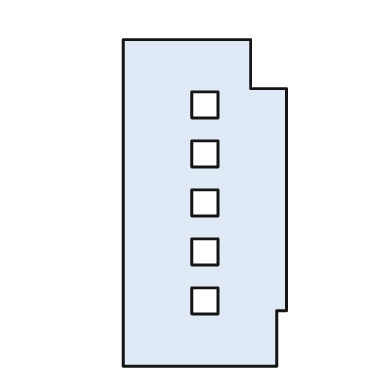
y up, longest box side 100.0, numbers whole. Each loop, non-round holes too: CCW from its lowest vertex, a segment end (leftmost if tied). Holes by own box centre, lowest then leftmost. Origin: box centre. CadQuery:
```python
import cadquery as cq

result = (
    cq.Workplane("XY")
    .moveTo(-25.0, -50.0)
    .lineTo(22.0, -50.0)
    .lineTo(22.0, -33.0)
    .lineTo(25.0, -33.0)
    .lineTo(25.0, 35.0)
    .lineTo(14.0, 35.0)
    .lineTo(14.0, 50.0)
    .lineTo(-25.0, 50.0)
    .close()
    .moveTo(-4.0, -34.0)
    .lineTo(4.0, -34.0)
    .lineTo(4.0, -26.0)
    .lineTo(-4.0, -26.0)
    .close()
    .moveTo(-4.0, -19.0)
    .lineTo(4.0, -19.0)
    .lineTo(4.0, -11.0)
    .lineTo(-4.0, -11.0)
    .close()
    .moveTo(-4.0, -4.0)
    .lineTo(4.0, -4.0)
    .lineTo(4.0, 4.0)
    .lineTo(-4.0, 4.0)
    .close()
    .moveTo(-4.0, 11.0)
    .lineTo(4.0, 11.0)
    .lineTo(4.0, 19.0)
    .lineTo(-4.0, 19.0)
    .close()
    .moveTo(-4.0, 26.0)
    .lineTo(4.0, 26.0)
    .lineTo(4.0, 34.0)
    .lineTo(-4.0, 34.0)
    .close()
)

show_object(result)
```